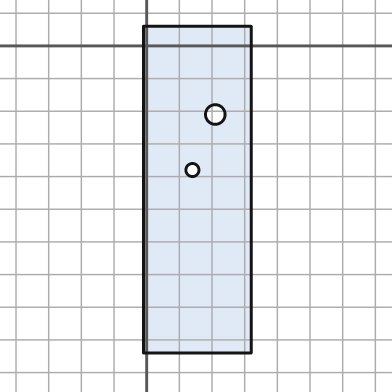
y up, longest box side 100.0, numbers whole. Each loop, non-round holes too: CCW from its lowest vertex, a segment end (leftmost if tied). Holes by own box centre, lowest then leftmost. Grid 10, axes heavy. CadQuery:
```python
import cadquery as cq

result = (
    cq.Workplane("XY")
    .moveTo(-1.0, -94.0)
    .lineTo(32.0, -94.0)
    .lineTo(32.0, 6.0)
    .lineTo(-1.0, 6.0)
    .close()
    .moveTo(14.0, -38.0)
    .circle(2.0)
    .moveTo(21.0, -21.0)
    .circle(3.0)
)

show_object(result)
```